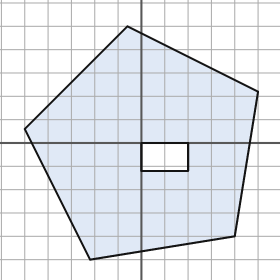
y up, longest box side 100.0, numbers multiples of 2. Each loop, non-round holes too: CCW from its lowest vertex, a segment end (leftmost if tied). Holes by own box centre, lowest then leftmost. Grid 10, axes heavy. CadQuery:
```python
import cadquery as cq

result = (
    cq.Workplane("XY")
    .moveTo(-22.0, -50.0)
    .lineTo(40.0, -40.0)
    .lineTo(50.0, 22.0)
    .lineTo(-6.0, 50.0)
    .lineTo(-50.0, 6.0)
    .close()
    .moveTo(0.0, -12.0)
    .lineTo(20.0, -12.0)
    .lineTo(20.0, 0.0)
    .lineTo(0.0, 0.0)
    .close()
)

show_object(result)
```